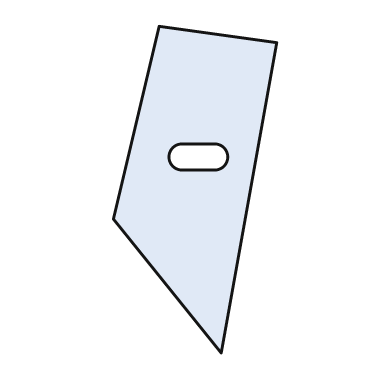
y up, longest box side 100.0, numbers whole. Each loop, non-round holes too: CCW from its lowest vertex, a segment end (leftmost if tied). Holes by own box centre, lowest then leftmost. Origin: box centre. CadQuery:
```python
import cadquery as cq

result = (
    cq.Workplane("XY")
    .moveTo(8.0, -50.0)
    .lineTo(25.0, 45.0)
    .lineTo(-11.0, 50.0)
    .lineTo(-25.0, -9.0)
    .close()
    .moveTo(-4.0, 6.0)
    .lineTo(6.0, 6.0)
    .threePointArc((10.0, 10.0), (6.0, 14.0))
    .lineTo(-4.0, 14.0)
    .threePointArc((-8.0, 10.0), (-4.0, 6.0))
    .close()
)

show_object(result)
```